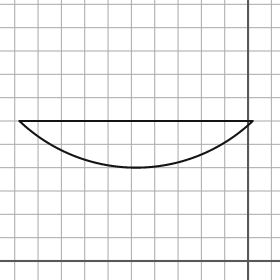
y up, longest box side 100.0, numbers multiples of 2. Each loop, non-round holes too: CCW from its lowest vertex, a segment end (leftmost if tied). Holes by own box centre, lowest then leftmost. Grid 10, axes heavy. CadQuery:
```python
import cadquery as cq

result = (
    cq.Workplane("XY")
    .moveTo(-98.0, 60.0)
    .threePointArc((-48.0, 40.0), (2.0, 60.0))
    .close()
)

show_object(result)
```